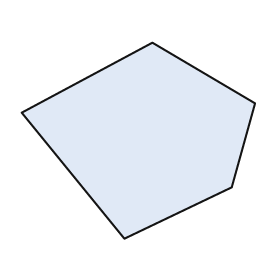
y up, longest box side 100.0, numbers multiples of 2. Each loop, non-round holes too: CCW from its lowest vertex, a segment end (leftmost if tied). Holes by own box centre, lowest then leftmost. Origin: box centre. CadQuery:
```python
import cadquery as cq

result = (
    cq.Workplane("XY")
    .moveTo(-6.0, -42.0)
    .lineTo(40.0, -20.0)
    .lineTo(50.0, 16.0)
    .lineTo(6.0, 42.0)
    .lineTo(-50.0, 12.0)
    .close()
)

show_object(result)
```